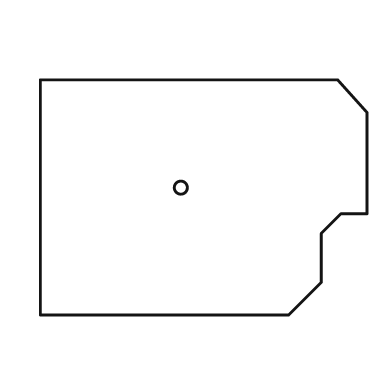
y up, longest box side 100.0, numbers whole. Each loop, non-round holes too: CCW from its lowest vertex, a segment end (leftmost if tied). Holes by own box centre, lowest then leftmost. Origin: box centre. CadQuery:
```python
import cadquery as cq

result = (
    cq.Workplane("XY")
    .moveTo(-50.0, -36.0)
    .lineTo(26.0, -36.0)
    .lineTo(36.0, -26.0)
    .lineTo(36.0, -11.0)
    .lineTo(42.0, -5.0)
    .lineTo(50.0, -5.0)
    .lineTo(50.0, 26.0)
    .lineTo(41.0, 36.0)
    .lineTo(-50.0, 36.0)
    .close()
    .moveTo(-7.0, 3.0)
    .circle(2.0)
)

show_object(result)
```